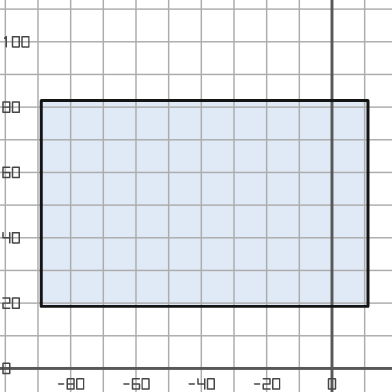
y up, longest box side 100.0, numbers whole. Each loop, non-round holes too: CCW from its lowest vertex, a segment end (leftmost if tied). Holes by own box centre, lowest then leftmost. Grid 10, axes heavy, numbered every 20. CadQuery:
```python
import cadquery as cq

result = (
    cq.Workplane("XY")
    .moveTo(-89.0, 19.0)
    .lineTo(11.0, 19.0)
    .lineTo(11.0, 82.0)
    .lineTo(-89.0, 82.0)
    .close()
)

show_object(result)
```